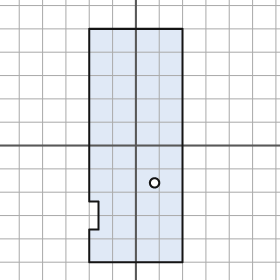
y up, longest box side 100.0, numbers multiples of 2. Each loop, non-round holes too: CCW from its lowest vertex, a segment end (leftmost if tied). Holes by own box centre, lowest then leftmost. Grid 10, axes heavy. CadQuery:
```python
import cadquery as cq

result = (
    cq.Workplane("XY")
    .moveTo(-20.0, -50.0)
    .lineTo(20.0, -50.0)
    .lineTo(20.0, 50.0)
    .lineTo(-20.0, 50.0)
    .lineTo(-20.0, -24.0)
    .lineTo(-16.0, -24.0)
    .lineTo(-16.0, -36.0)
    .lineTo(-20.0, -36.0)
    .close()
    .moveTo(8.0, -16.0)
    .circle(2.0)
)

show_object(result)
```